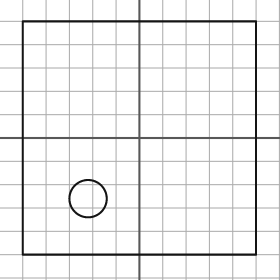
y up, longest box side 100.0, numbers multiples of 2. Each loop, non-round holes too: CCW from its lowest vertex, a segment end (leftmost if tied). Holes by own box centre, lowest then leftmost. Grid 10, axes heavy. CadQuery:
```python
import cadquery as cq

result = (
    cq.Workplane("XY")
    .moveTo(-50.0, -50.0)
    .lineTo(50.0, -50.0)
    .lineTo(50.0, 50.0)
    .lineTo(-50.0, 50.0)
    .close()
    .moveTo(-22.0, -26.0)
    .circle(8.0)
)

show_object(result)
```